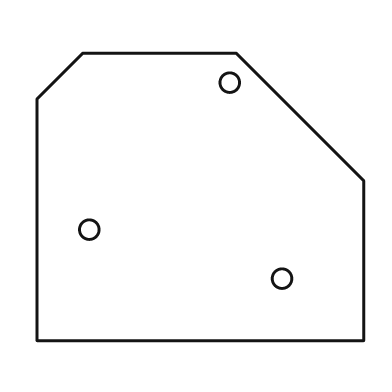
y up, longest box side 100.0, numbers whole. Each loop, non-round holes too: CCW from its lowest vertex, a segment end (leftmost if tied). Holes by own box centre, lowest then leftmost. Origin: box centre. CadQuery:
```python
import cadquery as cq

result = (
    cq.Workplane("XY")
    .moveTo(-50.0, -44.0)
    .lineTo(50.0, -44.0)
    .lineTo(50.0, 5.0)
    .lineTo(11.0, 44.0)
    .lineTo(-36.0, 44.0)
    .lineTo(-50.0, 30.0)
    .close()
    .moveTo(25.0, -25.0)
    .circle(3.0)
    .moveTo(-34.0, -10.0)
    .circle(3.0)
    .moveTo(9.0, 35.0)
    .circle(3.0)
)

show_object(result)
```